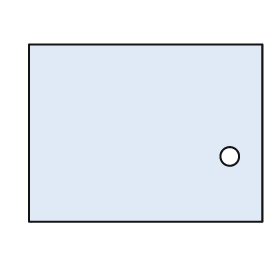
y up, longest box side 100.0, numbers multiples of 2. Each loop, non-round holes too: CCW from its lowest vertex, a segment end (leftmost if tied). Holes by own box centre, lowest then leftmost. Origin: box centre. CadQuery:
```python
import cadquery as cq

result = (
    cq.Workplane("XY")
    .moveTo(-50.0, -38.0)
    .lineTo(50.0, -38.0)
    .lineTo(50.0, 38.0)
    .lineTo(-50.0, 38.0)
    .close()
    .moveTo(36.0, -10.0)
    .circle(4.0)
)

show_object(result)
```